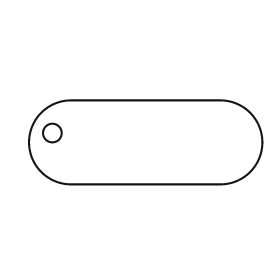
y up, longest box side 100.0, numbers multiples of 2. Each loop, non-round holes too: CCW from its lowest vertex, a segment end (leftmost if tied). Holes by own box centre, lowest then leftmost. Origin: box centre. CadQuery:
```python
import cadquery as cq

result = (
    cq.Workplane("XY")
    .moveTo(-32.0, -18.0)
    .lineTo(32.0, -18.0)
    .threePointArc((50.0, 0.0), (32.0, 18.0))
    .lineTo(-32.0, 18.0)
    .threePointArc((-50.0, 0.0), (-32.0, -18.0))
    .close()
    .moveTo(-40.0, 4.0)
    .circle(4.0)
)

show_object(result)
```